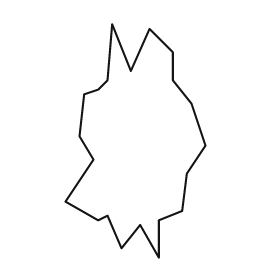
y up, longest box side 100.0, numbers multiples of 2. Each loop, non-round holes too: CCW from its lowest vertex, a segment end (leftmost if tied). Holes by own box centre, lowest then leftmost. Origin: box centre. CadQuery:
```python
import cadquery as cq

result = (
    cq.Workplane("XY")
    .moveTo(10.0, -50.0)
    .lineTo(10.0, -34.0)
    .lineTo(20.0, -30.0)
    .lineTo(22.0, -14.0)
    .lineTo(30.0, -2.0)
    .lineTo(24.0, 16.0)
    .lineTo(16.0, 26.0)
    .lineTo(16.0, 38.0)
    .lineTo(6.0, 48.0)
    .lineTo(-2.0, 30.0)
    .lineTo(-10.0, 50.0)
    .lineTo(-12.0, 26.0)
    .lineTo(-16.0, 22.0)
    .lineTo(-22.0, 20.0)
    .lineTo(-24.0, 2.0)
    .lineTo(-18.0, -8.0)
    .lineTo(-30.0, -26.0)
    .lineTo(-16.0, -34.0)
    .lineTo(-12.0, -32.0)
    .lineTo(-6.0, -46.0)
    .lineTo(2.0, -36.0)
    .close()
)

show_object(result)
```